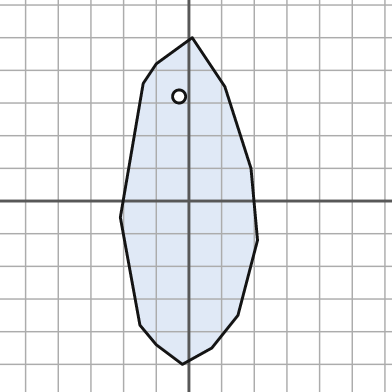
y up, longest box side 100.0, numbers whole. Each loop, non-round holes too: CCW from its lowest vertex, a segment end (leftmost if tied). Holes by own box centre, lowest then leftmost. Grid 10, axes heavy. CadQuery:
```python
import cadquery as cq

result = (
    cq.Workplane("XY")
    .moveTo(-2.0, -50.0)
    .lineTo(7.0, -45.0)
    .lineTo(15.0, -35.0)
    .lineTo(21.0, -12.0)
    .lineTo(19.0, 10.0)
    .lineTo(11.0, 35.0)
    .lineTo(1.0, 50.0)
    .lineTo(-10.0, 42.0)
    .lineTo(-14.0, 36.0)
    .lineTo(-21.0, -5.0)
    .lineTo(-15.0, -38.0)
    .lineTo(-10.0, -44.0)
    .close()
    .moveTo(-3.0, 32.0)
    .circle(2.0)
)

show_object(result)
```